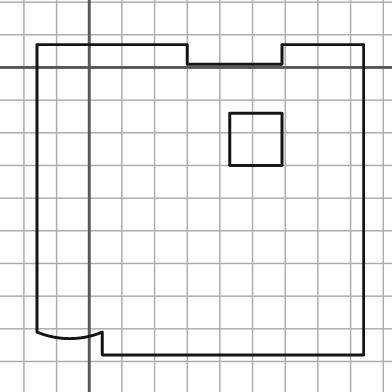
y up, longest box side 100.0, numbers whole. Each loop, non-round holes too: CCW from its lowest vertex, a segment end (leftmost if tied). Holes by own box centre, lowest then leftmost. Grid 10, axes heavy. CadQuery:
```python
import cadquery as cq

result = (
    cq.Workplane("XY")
    .moveTo(4.0, -88.0)
    .lineTo(84.0, -88.0)
    .lineTo(84.0, 7.0)
    .lineTo(59.0, 7.0)
    .lineTo(59.0, 1.0)
    .lineTo(30.0, 1.0)
    .lineTo(30.0, 7.0)
    .lineTo(-16.0, 7.0)
    .lineTo(-16.0, -81.0)
    .threePointArc((-6.0, -83.0), (4.0, -81.0))
    .close()
    .moveTo(43.0, -30.0)
    .lineTo(59.0, -30.0)
    .lineTo(59.0, -14.0)
    .lineTo(43.0, -14.0)
    .close()
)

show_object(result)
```